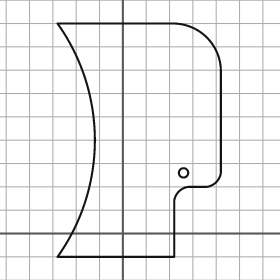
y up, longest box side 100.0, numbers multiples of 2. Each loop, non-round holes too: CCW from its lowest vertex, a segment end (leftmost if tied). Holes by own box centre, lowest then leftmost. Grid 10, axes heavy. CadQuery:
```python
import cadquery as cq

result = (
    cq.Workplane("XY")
    .moveTo(-28.0, -10.0)
    .lineTo(22.0, -10.0)
    .lineTo(22.0, 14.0)
    .threePointArc((24.0, 18.0), (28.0, 20.0))
    .lineTo(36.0, 20.0)
    .threePointArc((40.0, 22.0), (42.0, 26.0))
    .lineTo(42.0, 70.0)
    .threePointArc((36.0, 84.0), (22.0, 90.0))
    .lineTo(-28.0, 90.0)
    .threePointArc((-12.0, 40.0), (-28.0, -10.0))
    .close()
    .moveTo(26.0, 26.0)
    .circle(2.0)
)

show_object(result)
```